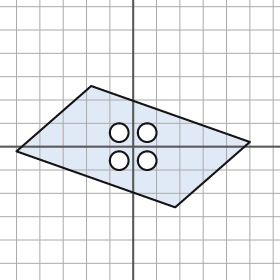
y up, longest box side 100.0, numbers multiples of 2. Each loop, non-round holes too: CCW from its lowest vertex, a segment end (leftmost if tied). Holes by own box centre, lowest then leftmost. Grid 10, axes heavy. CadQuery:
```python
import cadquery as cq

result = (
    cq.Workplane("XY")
    .moveTo(18.0, -26.0)
    .lineTo(50.0, 2.0)
    .lineTo(-18.0, 26.0)
    .lineTo(-50.0, -2.0)
    .close()
    .moveTo(-6.0, -6.0)
    .circle(4.0)
    .moveTo(6.0, -6.0)
    .circle(4.0)
    .moveTo(-6.0, 6.0)
    .circle(4.0)
    .moveTo(6.0, 6.0)
    .circle(4.0)
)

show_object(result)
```